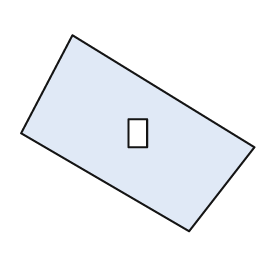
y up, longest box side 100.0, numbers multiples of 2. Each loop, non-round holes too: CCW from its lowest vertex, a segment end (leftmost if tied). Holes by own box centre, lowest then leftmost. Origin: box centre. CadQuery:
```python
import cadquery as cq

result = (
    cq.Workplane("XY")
    .moveTo(22.0, -42.0)
    .lineTo(50.0, -6.0)
    .lineTo(-28.0, 42.0)
    .lineTo(-50.0, 0.0)
    .close()
    .moveTo(-4.0, -6.0)
    .lineTo(4.0, -6.0)
    .lineTo(4.0, 6.0)
    .lineTo(-4.0, 6.0)
    .close()
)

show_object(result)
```